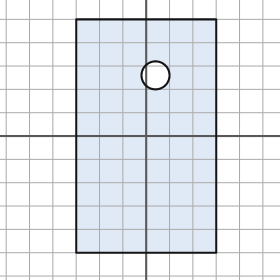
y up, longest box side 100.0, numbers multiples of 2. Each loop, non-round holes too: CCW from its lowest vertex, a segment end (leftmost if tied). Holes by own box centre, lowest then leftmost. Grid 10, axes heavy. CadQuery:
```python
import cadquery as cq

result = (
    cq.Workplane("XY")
    .moveTo(-30.0, -50.0)
    .lineTo(30.0, -50.0)
    .lineTo(30.0, 50.0)
    .lineTo(-30.0, 50.0)
    .close()
    .moveTo(4.0, 26.0)
    .circle(6.0)
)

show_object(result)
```